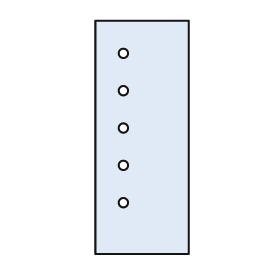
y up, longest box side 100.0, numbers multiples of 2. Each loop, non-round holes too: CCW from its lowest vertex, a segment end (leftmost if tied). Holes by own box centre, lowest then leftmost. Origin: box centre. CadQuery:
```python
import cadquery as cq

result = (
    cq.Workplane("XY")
    .moveTo(-20.0, -50.0)
    .lineTo(20.0, -50.0)
    .lineTo(20.0, 50.0)
    .lineTo(-20.0, 50.0)
    .close()
    .moveTo(-8.0, -28.0)
    .circle(2.0)
    .moveTo(-8.0, -12.0)
    .circle(2.0)
    .moveTo(-8.0, 4.0)
    .circle(2.0)
    .moveTo(-8.0, 20.0)
    .circle(2.0)
    .moveTo(-8.0, 36.0)
    .circle(2.0)
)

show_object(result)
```